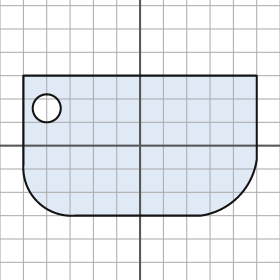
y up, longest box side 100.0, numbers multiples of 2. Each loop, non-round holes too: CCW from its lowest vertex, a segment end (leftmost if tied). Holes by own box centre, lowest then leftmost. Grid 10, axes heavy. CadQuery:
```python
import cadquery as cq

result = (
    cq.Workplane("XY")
    .moveTo(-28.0, -30.0)
    .lineTo(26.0, -30.0)
    .threePointArc((42.0, -22.0), (50.0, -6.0))
    .lineTo(50.0, 30.0)
    .lineTo(-50.0, 30.0)
    .lineTo(-50.0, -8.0)
    .threePointArc((-44.0, -24.0), (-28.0, -30.0))
    .close()
    .moveTo(-40.0, 16.0)
    .circle(6.0)
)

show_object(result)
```